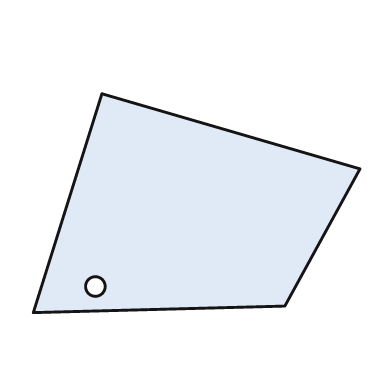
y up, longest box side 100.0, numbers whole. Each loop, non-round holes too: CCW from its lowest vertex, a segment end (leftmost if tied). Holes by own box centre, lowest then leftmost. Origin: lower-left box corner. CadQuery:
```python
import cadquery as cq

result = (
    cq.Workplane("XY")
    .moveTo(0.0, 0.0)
    .lineTo(77.0, 2.0)
    .lineTo(100.0, 44.0)
    .lineTo(21.0, 67.0)
    .close()
    .moveTo(19.0, 8.0)
    .circle(3.0)
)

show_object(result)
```